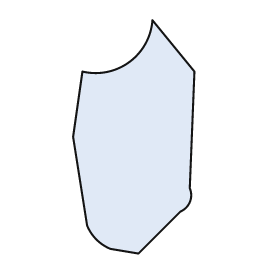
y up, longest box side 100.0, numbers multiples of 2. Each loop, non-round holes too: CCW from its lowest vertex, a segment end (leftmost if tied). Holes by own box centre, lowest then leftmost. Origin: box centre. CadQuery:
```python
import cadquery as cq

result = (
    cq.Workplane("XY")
    .moveTo(2.0, -50.0)
    .lineTo(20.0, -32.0)
    .threePointArc((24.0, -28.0), (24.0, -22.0))
    .lineTo(26.0, 28.0)
    .lineTo(8.0, 50.0)
    .threePointArc((-2.0, 32.0), (-22.0, 28.0))
    .lineTo(-26.0, 0.0)
    .lineTo(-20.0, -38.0)
    .threePointArc((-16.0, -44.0), (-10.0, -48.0))
    .close()
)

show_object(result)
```